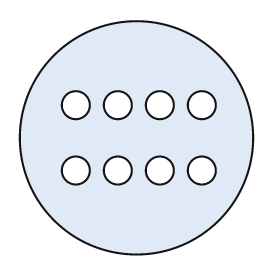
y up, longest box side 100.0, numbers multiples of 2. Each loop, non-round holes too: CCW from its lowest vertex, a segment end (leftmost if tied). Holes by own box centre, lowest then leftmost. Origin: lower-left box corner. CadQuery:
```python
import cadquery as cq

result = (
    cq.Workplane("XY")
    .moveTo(50.0, 50.0)
    .circle(50.0)
    .moveTo(24.0, 36.0)
    .circle(6.0)
    .moveTo(42.0, 36.0)
    .circle(6.0)
    .moveTo(60.0, 36.0)
    .circle(6.0)
    .moveTo(78.0, 36.0)
    .circle(6.0)
    .moveTo(24.0, 64.0)
    .circle(6.0)
    .moveTo(42.0, 64.0)
    .circle(6.0)
    .moveTo(60.0, 64.0)
    .circle(6.0)
    .moveTo(78.0, 64.0)
    .circle(6.0)
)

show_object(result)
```